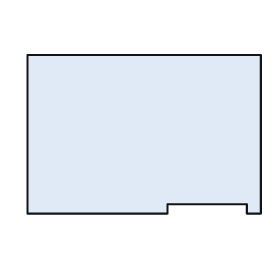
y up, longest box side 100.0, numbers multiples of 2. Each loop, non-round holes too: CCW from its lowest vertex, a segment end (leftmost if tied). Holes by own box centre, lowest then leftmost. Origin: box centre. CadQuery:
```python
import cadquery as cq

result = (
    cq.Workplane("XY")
    .moveTo(-50.0, -34.0)
    .lineTo(10.0, -34.0)
    .lineTo(10.0, -30.0)
    .lineTo(44.0, -30.0)
    .lineTo(44.0, -34.0)
    .lineTo(50.0, -34.0)
    .lineTo(50.0, 34.0)
    .lineTo(-50.0, 34.0)
    .close()
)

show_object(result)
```